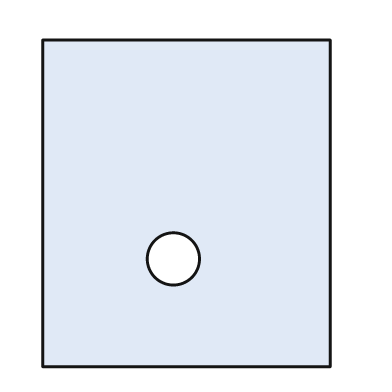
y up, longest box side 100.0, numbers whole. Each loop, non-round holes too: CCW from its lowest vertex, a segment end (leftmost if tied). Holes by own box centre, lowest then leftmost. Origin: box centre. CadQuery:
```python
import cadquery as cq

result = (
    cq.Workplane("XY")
    .moveTo(-44.0, -50.0)
    .lineTo(44.0, -50.0)
    .lineTo(44.0, 50.0)
    .lineTo(-44.0, 50.0)
    .close()
    .moveTo(-4.0, -17.0)
    .circle(8.0)
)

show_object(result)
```